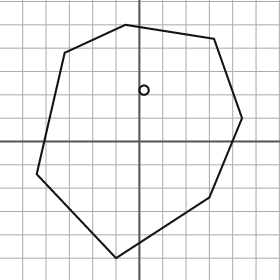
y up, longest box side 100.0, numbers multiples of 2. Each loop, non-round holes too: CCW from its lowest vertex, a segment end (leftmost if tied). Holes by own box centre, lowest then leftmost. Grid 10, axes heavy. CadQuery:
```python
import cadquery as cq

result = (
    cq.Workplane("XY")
    .moveTo(-10.0, -50.0)
    .lineTo(30.0, -24.0)
    .lineTo(44.0, 10.0)
    .lineTo(32.0, 44.0)
    .lineTo(-6.0, 50.0)
    .lineTo(-32.0, 38.0)
    .lineTo(-44.0, -14.0)
    .close()
    .moveTo(2.0, 22.0)
    .circle(2.0)
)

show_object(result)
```